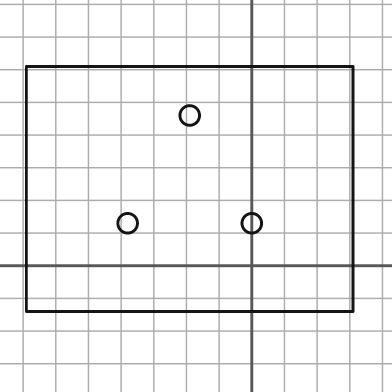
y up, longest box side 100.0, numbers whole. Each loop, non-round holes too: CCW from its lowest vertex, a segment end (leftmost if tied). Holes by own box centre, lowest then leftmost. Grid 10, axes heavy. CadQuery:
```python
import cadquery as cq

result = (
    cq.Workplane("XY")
    .moveTo(-69.0, -14.0)
    .lineTo(31.0, -14.0)
    .lineTo(31.0, 61.0)
    .lineTo(-69.0, 61.0)
    .close()
    .moveTo(-38.0, 13.0)
    .circle(3.0)
    .moveTo(0.0, 13.0)
    .circle(3.0)
    .moveTo(-19.0, 46.0)
    .circle(3.0)
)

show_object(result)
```